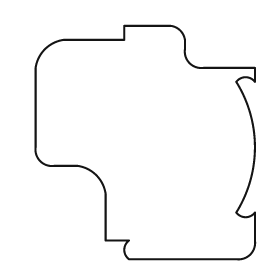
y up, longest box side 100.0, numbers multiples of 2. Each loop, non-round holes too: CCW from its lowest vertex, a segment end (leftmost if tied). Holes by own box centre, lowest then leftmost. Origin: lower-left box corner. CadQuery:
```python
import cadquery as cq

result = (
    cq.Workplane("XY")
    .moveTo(40.0, 0.0)
    .lineTo(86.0, 0.0)
    .threePointArc((92.0, 2.0), (94.0, 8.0))
    .lineTo(94.0, 20.0)
    .threePointArc((90.0, 18.0), (86.0, 20.0))
    .threePointArc((94.0, 48.0), (86.0, 76.0))
    .threePointArc((90.0, 78.0), (94.0, 76.0))
    .lineTo(94.0, 82.0)
    .lineTo(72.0, 82.0)
    .threePointArc((66.0, 84.0), (64.0, 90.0))
    .lineTo(64.0, 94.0)
    .threePointArc((62.0, 98.0), (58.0, 100.0))
    .lineTo(38.0, 100.0)
    .lineTo(38.0, 94.0)
    .lineTo(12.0, 94.0)
    .threePointArc((4.0, 90.0), (0.0, 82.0))
    .lineTo(0.0, 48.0)
    .threePointArc((2.0, 42.0), (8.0, 40.0))
    .lineTo(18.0, 40.0)
    .threePointArc((26.0, 36.0), (30.0, 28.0))
    .lineTo(30.0, 8.0)
    .lineTo(40.0, 8.0)
    .threePointArc((38.0, 4.0), (40.0, 0.0))
    .close()
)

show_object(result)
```